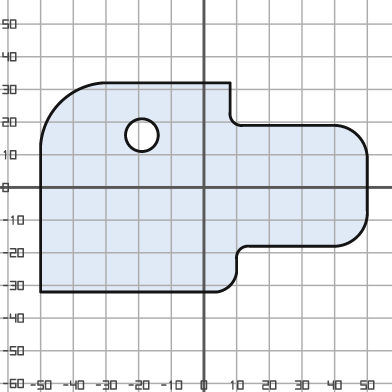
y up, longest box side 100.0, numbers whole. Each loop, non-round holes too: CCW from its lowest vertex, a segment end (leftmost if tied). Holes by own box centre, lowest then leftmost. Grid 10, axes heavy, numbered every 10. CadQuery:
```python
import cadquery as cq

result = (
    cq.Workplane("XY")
    .moveTo(-50.0, -32.0)
    .lineTo(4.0, -32.0)
    .threePointArc((8.0, -30.0), (10.0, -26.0))
    .lineTo(10.0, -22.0)
    .threePointArc((11.0, -19.0), (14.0, -18.0))
    .lineTo(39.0, -18.0)
    .threePointArc((47.0, -15.0), (50.0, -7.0))
    .lineTo(50.0, 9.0)
    .threePointArc((47.0, 16.0), (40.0, 19.0))
    .lineTo(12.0, 19.0)
    .threePointArc((9.0, 20.0), (8.0, 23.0))
    .lineTo(8.0, 32.0)
    .lineTo(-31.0, 32.0)
    .threePointArc((-44.0, 26.0), (-50.0, 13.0))
    .close()
    .moveTo(-19.0, 16.0)
    .circle(5.0)
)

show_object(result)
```